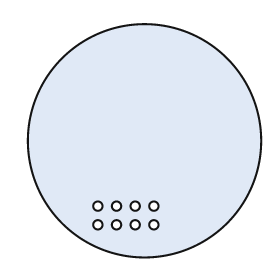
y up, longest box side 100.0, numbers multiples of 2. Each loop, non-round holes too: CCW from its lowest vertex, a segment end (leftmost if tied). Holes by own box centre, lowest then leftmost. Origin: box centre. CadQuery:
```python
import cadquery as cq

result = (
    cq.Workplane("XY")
    .moveTo(0.0, 0.0)
    .circle(50.0)
    .moveTo(-20.0, -36.0)
    .circle(2.0)
    .moveTo(-12.0, -36.0)
    .circle(2.0)
    .moveTo(-4.0, -36.0)
    .circle(2.0)
    .moveTo(4.0, -36.0)
    .circle(2.0)
    .moveTo(-20.0, -28.0)
    .circle(2.0)
    .moveTo(-12.0, -28.0)
    .circle(2.0)
    .moveTo(-4.0, -28.0)
    .circle(2.0)
    .moveTo(4.0, -28.0)
    .circle(2.0)
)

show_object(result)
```